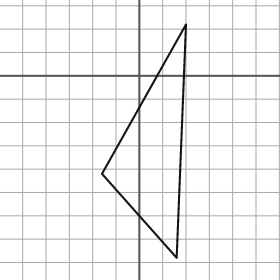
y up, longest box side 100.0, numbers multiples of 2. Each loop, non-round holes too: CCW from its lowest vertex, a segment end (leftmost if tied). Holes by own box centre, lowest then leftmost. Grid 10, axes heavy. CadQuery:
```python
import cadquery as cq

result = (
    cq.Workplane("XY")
    .moveTo(16.0, -78.0)
    .lineTo(20.0, 22.0)
    .lineTo(-16.0, -42.0)
    .close()
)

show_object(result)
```